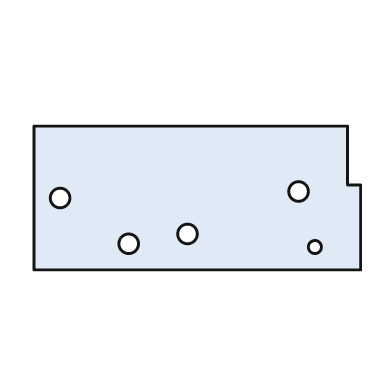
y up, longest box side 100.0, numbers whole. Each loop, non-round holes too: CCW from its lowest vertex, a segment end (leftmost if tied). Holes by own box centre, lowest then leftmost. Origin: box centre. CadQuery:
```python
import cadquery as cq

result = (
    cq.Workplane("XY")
    .moveTo(-50.0, -22.0)
    .lineTo(50.0, -22.0)
    .lineTo(50.0, 4.0)
    .lineTo(46.0, 4.0)
    .lineTo(46.0, 22.0)
    .lineTo(-50.0, 22.0)
    .close()
    .moveTo(36.0, -15.0)
    .circle(2.0)
    .moveTo(-21.0, -14.0)
    .circle(3.0)
    .moveTo(-3.0, -11.0)
    .circle(3.0)
    .moveTo(-42.0, 0.0)
    .circle(3.0)
    .moveTo(31.0, 2.0)
    .circle(3.0)
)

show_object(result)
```